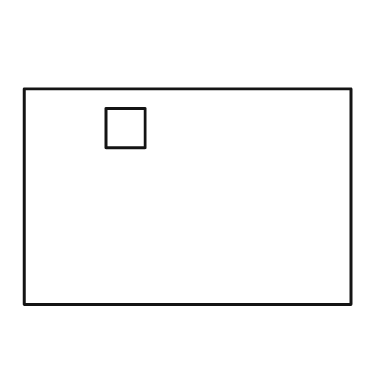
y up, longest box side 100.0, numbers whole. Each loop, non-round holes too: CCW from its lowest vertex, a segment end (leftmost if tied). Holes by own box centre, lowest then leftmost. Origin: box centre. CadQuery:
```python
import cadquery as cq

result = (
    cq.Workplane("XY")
    .moveTo(-50.0, -33.0)
    .lineTo(50.0, -33.0)
    .lineTo(50.0, 33.0)
    .lineTo(-50.0, 33.0)
    .close()
    .moveTo(-25.0, 15.0)
    .lineTo(-13.0, 15.0)
    .lineTo(-13.0, 27.0)
    .lineTo(-25.0, 27.0)
    .close()
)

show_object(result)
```